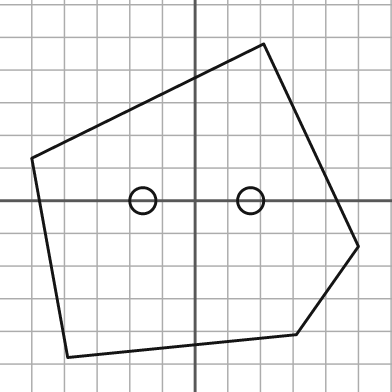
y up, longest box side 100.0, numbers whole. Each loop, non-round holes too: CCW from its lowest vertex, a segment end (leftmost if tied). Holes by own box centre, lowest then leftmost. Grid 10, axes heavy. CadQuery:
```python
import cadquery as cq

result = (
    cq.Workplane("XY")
    .moveTo(-39.0, -48.0)
    .lineTo(31.0, -41.0)
    .lineTo(50.0, -14.0)
    .lineTo(21.0, 48.0)
    .lineTo(-50.0, 13.0)
    .close()
    .moveTo(-16.0, 0.0)
    .circle(4.0)
    .moveTo(17.0, 0.0)
    .circle(4.0)
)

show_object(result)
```